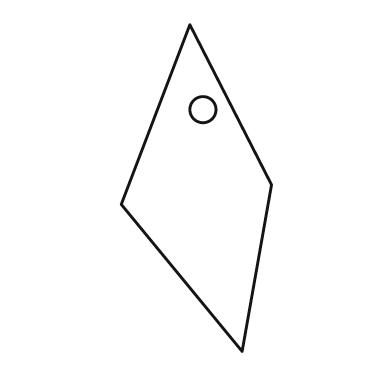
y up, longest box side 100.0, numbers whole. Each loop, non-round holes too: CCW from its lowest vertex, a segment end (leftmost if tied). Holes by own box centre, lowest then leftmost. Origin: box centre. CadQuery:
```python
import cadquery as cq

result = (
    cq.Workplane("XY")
    .moveTo(14.0, -50.0)
    .lineTo(23.0, 1.0)
    .lineTo(-2.0, 50.0)
    .lineTo(-23.0, -5.0)
    .close()
    .moveTo(2.0, 24.0)
    .circle(4.0)
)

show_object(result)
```